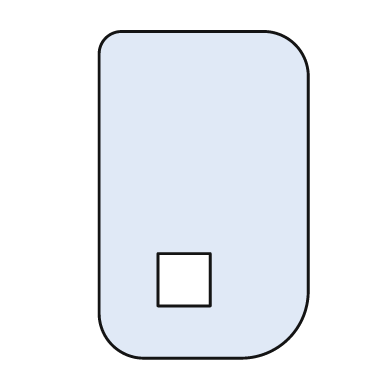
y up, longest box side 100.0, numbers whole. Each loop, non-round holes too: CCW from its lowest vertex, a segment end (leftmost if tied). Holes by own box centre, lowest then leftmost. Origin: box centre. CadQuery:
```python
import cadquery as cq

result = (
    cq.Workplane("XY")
    .moveTo(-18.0, -50.0)
    .lineTo(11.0, -50.0)
    .threePointArc((26.0, -44.0), (32.0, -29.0))
    .lineTo(32.0, 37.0)
    .threePointArc((28.0, 46.0), (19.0, 50.0))
    .lineTo(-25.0, 50.0)
    .threePointArc((-30.0, 48.0), (-32.0, 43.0))
    .lineTo(-32.0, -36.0)
    .threePointArc((-28.0, -46.0), (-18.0, -50.0))
    .close()
    .moveTo(-14.0, -34.0)
    .lineTo(2.0, -34.0)
    .lineTo(2.0, -18.0)
    .lineTo(-14.0, -18.0)
    .close()
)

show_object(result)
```